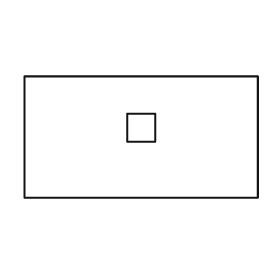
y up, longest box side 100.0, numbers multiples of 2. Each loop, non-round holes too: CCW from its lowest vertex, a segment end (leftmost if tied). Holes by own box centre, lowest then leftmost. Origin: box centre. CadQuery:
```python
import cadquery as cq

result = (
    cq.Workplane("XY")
    .moveTo(-50.0, -26.0)
    .lineTo(50.0, -26.0)
    .lineTo(50.0, 26.0)
    .lineTo(-50.0, 26.0)
    .close()
    .moveTo(-6.0, -2.0)
    .lineTo(6.0, -2.0)
    .lineTo(6.0, 10.0)
    .lineTo(-6.0, 10.0)
    .close()
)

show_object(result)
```